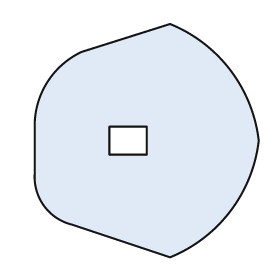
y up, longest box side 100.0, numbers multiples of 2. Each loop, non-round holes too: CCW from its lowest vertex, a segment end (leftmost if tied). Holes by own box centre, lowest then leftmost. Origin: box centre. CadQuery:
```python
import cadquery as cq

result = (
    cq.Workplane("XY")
    .moveTo(10.0, -50.0)
    .threePointArc((36.0, -30.0), (48.0, 0.0))
    .threePointArc((36.0, 30.0), (10.0, 50.0))
    .lineTo(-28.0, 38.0)
    .threePointArc((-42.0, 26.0), (-48.0, 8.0))
    .lineTo(-48.0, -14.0)
    .threePointArc((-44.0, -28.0), (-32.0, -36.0))
    .close()
    .moveTo(-16.0, -6.0)
    .lineTo(0.0, -6.0)
    .lineTo(0.0, 6.0)
    .lineTo(-16.0, 6.0)
    .close()
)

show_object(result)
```